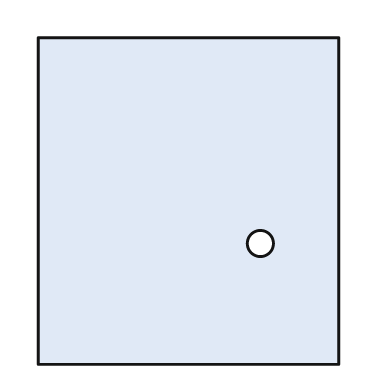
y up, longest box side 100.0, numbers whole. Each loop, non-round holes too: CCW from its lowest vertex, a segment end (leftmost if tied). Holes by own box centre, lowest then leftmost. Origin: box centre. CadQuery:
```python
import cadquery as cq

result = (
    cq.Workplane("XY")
    .moveTo(-46.0, -50.0)
    .lineTo(46.0, -50.0)
    .lineTo(46.0, 50.0)
    .lineTo(-46.0, 50.0)
    .close()
    .moveTo(22.0, -13.0)
    .circle(4.0)
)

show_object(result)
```